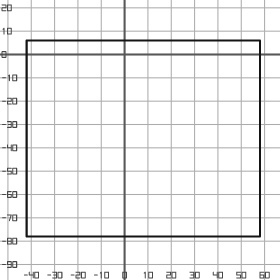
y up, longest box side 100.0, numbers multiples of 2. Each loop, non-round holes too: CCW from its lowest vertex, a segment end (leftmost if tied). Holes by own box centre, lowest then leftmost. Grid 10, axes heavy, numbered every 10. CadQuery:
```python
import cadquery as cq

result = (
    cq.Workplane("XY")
    .moveTo(-42.0, -78.0)
    .lineTo(58.0, -78.0)
    .lineTo(58.0, 6.0)
    .lineTo(-42.0, 6.0)
    .close()
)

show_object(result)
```